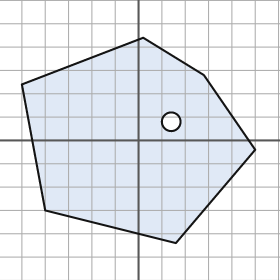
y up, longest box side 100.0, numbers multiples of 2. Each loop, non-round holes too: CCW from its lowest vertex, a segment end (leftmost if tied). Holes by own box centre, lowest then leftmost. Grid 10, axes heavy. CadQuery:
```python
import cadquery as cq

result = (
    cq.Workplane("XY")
    .moveTo(16.0, -44.0)
    .lineTo(50.0, -4.0)
    .lineTo(28.0, 28.0)
    .lineTo(2.0, 44.0)
    .lineTo(-50.0, 24.0)
    .lineTo(-40.0, -30.0)
    .close()
    .moveTo(14.0, 8.0)
    .circle(4.0)
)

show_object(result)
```